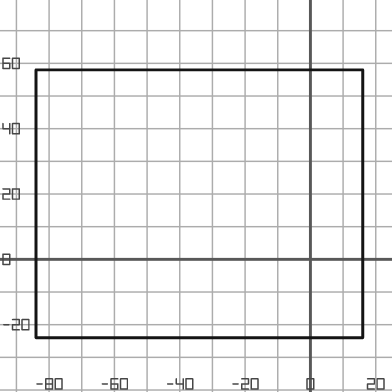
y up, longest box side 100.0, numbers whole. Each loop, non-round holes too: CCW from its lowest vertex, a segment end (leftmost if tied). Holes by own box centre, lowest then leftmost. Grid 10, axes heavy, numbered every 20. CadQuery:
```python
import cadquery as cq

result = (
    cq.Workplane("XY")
    .moveTo(-84.0, -24.0)
    .lineTo(16.0, -24.0)
    .lineTo(16.0, 58.0)
    .lineTo(-84.0, 58.0)
    .close()
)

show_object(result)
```